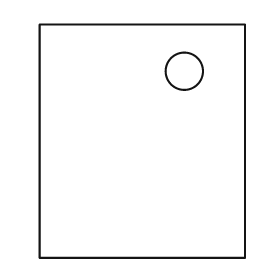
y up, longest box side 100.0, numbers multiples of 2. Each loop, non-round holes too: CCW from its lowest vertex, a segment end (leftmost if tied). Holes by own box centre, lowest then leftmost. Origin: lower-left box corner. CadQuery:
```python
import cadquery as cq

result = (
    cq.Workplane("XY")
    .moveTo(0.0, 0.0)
    .lineTo(88.0, 0.0)
    .lineTo(88.0, 100.0)
    .lineTo(0.0, 100.0)
    .close()
    .moveTo(62.0, 80.0)
    .circle(8.0)
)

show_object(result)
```